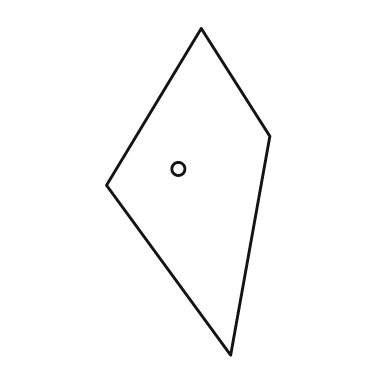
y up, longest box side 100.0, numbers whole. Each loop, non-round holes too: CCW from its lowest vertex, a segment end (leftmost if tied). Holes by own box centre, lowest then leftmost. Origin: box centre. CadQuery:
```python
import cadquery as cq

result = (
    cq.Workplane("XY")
    .moveTo(13.0, -50.0)
    .lineTo(25.0, 17.0)
    .lineTo(4.0, 50.0)
    .lineTo(-25.0, 2.0)
    .close()
    .moveTo(-3.0, 7.0)
    .circle(2.0)
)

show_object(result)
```